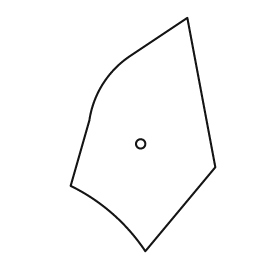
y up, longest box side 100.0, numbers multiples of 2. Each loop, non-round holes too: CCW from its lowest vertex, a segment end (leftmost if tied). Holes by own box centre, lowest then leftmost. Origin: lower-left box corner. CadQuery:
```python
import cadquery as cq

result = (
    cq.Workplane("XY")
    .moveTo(32.0, 0.0)
    .lineTo(62.0, 36.0)
    .lineTo(50.0, 100.0)
    .lineTo(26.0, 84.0)
    .threePointArc((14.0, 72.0), (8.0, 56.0))
    .lineTo(0.0, 28.0)
    .threePointArc((18.0, 16.0), (32.0, 0.0))
    .close()
    .moveTo(30.0, 46.0)
    .circle(2.0)
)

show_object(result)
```